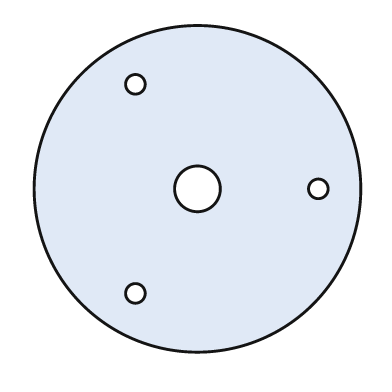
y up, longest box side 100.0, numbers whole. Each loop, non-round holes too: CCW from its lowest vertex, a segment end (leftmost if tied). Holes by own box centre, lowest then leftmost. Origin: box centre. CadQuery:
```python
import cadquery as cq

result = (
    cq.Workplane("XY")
    .moveTo(0.0, 0.0)
    .circle(50.0)
    .moveTo(-19.0, -32.0)
    .circle(3.0)
    .moveTo(0.0, 0.0)
    .circle(7.0)
    .moveTo(37.0, 0.0)
    .circle(3.0)
    .moveTo(-19.0, 32.0)
    .circle(3.0)
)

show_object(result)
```